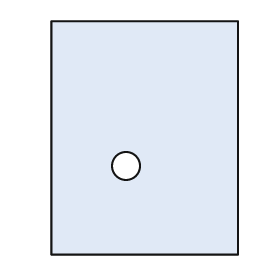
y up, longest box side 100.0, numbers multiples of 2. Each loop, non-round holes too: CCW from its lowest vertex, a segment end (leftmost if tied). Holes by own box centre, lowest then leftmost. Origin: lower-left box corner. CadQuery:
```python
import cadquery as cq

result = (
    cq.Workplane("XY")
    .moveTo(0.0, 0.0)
    .lineTo(80.0, 0.0)
    .lineTo(80.0, 100.0)
    .lineTo(0.0, 100.0)
    .close()
    .moveTo(32.0, 38.0)
    .circle(6.0)
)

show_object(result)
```